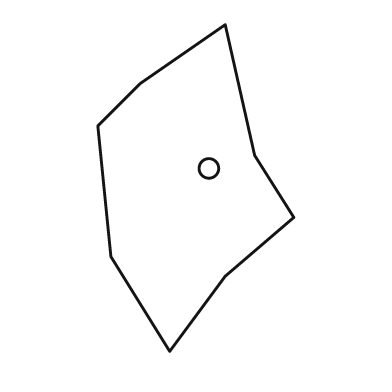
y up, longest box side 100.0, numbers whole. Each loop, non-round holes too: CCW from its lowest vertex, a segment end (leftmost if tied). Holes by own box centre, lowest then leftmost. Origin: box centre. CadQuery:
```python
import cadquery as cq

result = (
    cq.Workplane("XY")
    .moveTo(-8.0, -50.0)
    .lineTo(9.0, -27.0)
    .lineTo(30.0, -9.0)
    .lineTo(18.0, 10.0)
    .lineTo(9.0, 50.0)
    .lineTo(-17.0, 32.0)
    .lineTo(-30.0, 19.0)
    .lineTo(-26.0, -21.0)
    .close()
    .moveTo(4.0, 6.0)
    .circle(3.0)
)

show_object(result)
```